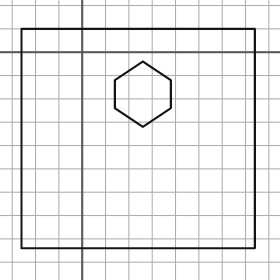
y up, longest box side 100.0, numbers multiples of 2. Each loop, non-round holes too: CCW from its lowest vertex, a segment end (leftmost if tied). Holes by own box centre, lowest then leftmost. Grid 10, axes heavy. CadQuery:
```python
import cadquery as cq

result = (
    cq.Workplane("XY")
    .moveTo(-26.0, -84.0)
    .lineTo(74.0, -84.0)
    .lineTo(74.0, 10.0)
    .lineTo(-26.0, 10.0)
    .close()
    .moveTo(26.0, -32.0)
    .lineTo(38.0, -24.0)
    .lineTo(38.0, -12.0)
    .lineTo(26.0, -4.0)
    .lineTo(14.0, -12.0)
    .lineTo(14.0, -24.0)
    .close()
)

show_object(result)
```